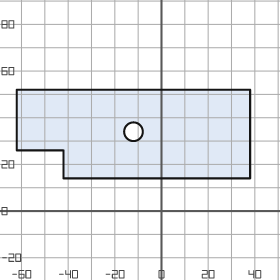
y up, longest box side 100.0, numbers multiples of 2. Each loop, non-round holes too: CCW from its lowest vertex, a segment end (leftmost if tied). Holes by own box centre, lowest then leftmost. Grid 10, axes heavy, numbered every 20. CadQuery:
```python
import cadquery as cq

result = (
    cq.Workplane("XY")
    .moveTo(-42.0, 14.0)
    .lineTo(38.0, 14.0)
    .lineTo(38.0, 52.0)
    .lineTo(-62.0, 52.0)
    .lineTo(-62.0, 26.0)
    .lineTo(-42.0, 26.0)
    .close()
    .moveTo(-12.0, 34.0)
    .circle(4.0)
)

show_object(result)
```